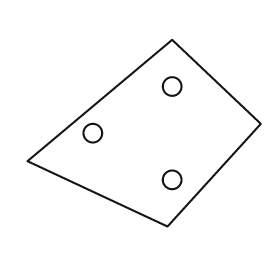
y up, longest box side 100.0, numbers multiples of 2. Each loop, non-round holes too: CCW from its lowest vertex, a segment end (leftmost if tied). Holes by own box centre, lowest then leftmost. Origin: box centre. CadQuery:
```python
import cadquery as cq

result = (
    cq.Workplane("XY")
    .moveTo(10.0, -40.0)
    .lineTo(50.0, 4.0)
    .lineTo(12.0, 40.0)
    .lineTo(-50.0, -12.0)
    .close()
    .moveTo(12.0, -20.0)
    .circle(4.0)
    .moveTo(-22.0, 0.0)
    .circle(4.0)
    .moveTo(12.0, 20.0)
    .circle(4.0)
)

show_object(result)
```